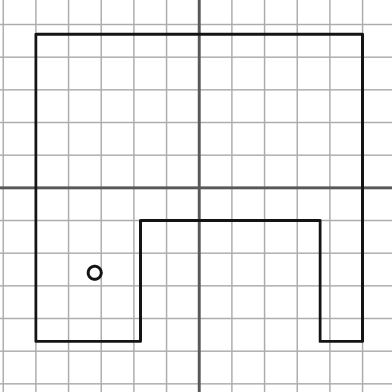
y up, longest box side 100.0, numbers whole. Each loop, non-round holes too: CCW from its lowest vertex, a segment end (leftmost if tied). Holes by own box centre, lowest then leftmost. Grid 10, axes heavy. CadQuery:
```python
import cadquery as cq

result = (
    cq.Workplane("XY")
    .moveTo(-50.0, -47.0)
    .lineTo(-18.0, -47.0)
    .lineTo(-18.0, -10.0)
    .lineTo(37.0, -10.0)
    .lineTo(37.0, -47.0)
    .lineTo(50.0, -47.0)
    .lineTo(50.0, 47.0)
    .lineTo(-50.0, 47.0)
    .close()
    .moveTo(-32.0, -26.0)
    .circle(2.0)
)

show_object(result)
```